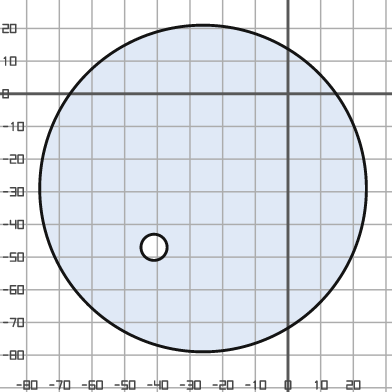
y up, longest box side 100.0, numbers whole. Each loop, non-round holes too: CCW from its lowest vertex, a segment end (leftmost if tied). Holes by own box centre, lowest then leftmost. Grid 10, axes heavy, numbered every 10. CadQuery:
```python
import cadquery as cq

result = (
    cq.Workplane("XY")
    .moveTo(-26.0, -29.0)
    .circle(50.0)
    .moveTo(-41.0, -47.0)
    .circle(4.0)
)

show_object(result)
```